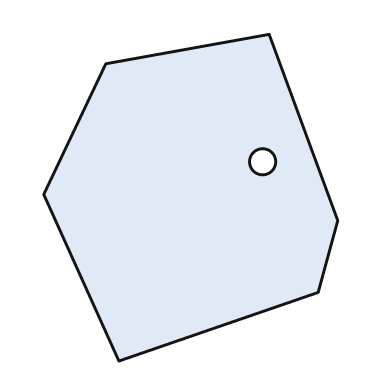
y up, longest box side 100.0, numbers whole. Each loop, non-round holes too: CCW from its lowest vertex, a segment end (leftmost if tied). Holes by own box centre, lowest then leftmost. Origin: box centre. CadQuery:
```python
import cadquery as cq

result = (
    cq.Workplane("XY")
    .moveTo(-22.0, -50.0)
    .lineTo(39.0, -29.0)
    .lineTo(45.0, -7.0)
    .lineTo(24.0, 50.0)
    .lineTo(-26.0, 41.0)
    .lineTo(-45.0, 1.0)
    .close()
    .moveTo(22.0, 11.0)
    .circle(4.0)
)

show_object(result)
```